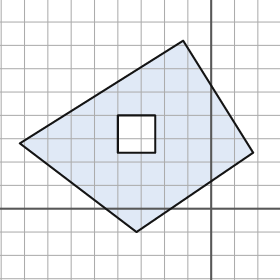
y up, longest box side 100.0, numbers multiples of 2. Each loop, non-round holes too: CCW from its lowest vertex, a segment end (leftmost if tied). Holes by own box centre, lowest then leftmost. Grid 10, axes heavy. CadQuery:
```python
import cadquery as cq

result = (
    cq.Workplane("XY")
    .moveTo(-32.0, -10.0)
    .lineTo(18.0, 24.0)
    .lineTo(-12.0, 72.0)
    .lineTo(-82.0, 28.0)
    .close()
    .moveTo(-40.0, 24.0)
    .lineTo(-24.0, 24.0)
    .lineTo(-24.0, 40.0)
    .lineTo(-40.0, 40.0)
    .close()
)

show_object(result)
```